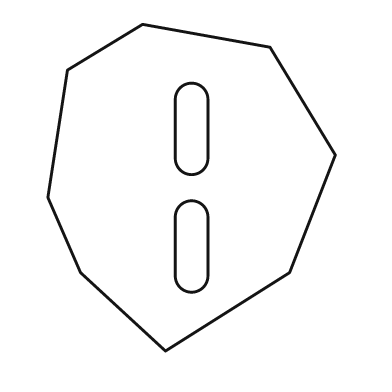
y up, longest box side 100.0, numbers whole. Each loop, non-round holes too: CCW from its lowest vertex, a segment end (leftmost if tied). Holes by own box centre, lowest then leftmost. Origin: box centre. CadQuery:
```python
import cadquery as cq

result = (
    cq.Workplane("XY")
    .moveTo(-8.0, -50.0)
    .lineTo(30.0, -26.0)
    .lineTo(44.0, 10.0)
    .lineTo(24.0, 43.0)
    .lineTo(-15.0, 50.0)
    .lineTo(-38.0, 36.0)
    .lineTo(-44.0, -3.0)
    .lineTo(-34.0, -26.0)
    .close()
    .moveTo(-5.0, -27.0)
    .threePointArc((0.0, -32.0), (5.0, -27.0))
    .lineTo(5.0, -9.0)
    .threePointArc((0.0, -4.0), (-5.0, -9.0))
    .close()
    .moveTo(-5.0, 9.0)
    .threePointArc((0.0, 4.0), (5.0, 9.0))
    .lineTo(5.0, 27.0)
    .threePointArc((0.0, 32.0), (-5.0, 27.0))
    .close()
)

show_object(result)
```